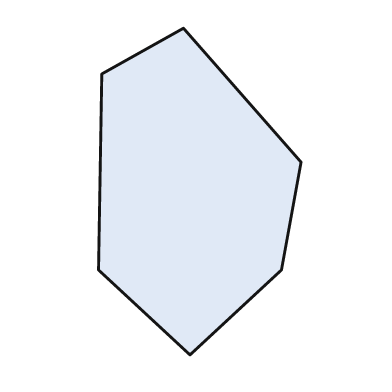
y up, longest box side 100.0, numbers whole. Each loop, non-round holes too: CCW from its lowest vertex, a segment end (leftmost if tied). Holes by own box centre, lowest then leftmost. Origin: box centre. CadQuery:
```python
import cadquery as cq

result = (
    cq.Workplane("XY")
    .moveTo(-3.0, -50.0)
    .lineTo(25.0, -24.0)
    .lineTo(31.0, 9.0)
    .lineTo(-5.0, 50.0)
    .lineTo(-30.0, 36.0)
    .lineTo(-31.0, -24.0)
    .close()
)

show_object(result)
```